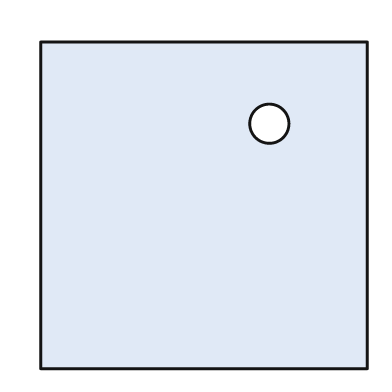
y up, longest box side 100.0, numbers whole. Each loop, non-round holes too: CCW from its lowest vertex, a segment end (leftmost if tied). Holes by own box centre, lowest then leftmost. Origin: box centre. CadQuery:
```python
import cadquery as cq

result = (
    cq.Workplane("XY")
    .moveTo(-50.0, -50.0)
    .lineTo(50.0, -50.0)
    .lineTo(50.0, 50.0)
    .lineTo(-50.0, 50.0)
    .close()
    .moveTo(20.0, 25.0)
    .circle(6.0)
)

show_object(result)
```